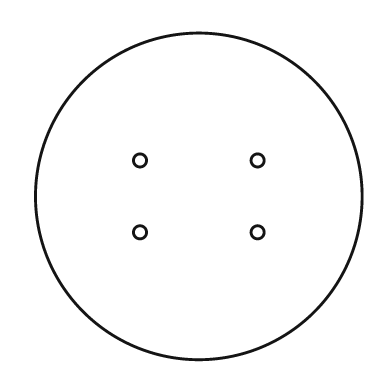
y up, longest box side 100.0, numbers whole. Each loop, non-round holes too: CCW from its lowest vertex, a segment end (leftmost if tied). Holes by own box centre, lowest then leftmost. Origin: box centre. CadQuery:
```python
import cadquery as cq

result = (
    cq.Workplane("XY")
    .moveTo(0.0, 0.0)
    .circle(50.0)
    .moveTo(-18.0, -11.0)
    .circle(2.0)
    .moveTo(18.0, -11.0)
    .circle(2.0)
    .moveTo(-18.0, 11.0)
    .circle(2.0)
    .moveTo(18.0, 11.0)
    .circle(2.0)
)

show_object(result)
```